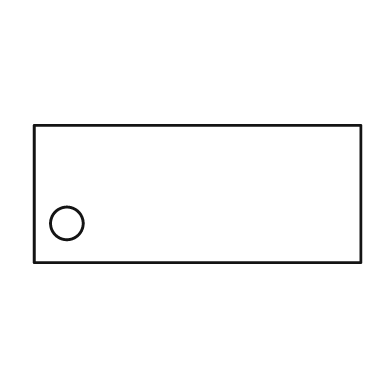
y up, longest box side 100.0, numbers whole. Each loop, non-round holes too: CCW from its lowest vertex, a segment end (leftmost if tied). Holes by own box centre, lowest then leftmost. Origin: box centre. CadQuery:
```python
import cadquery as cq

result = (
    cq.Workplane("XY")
    .moveTo(-50.0, -21.0)
    .lineTo(50.0, -21.0)
    .lineTo(50.0, 21.0)
    .lineTo(-50.0, 21.0)
    .close()
    .moveTo(-40.0, -9.0)
    .circle(5.0)
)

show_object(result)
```